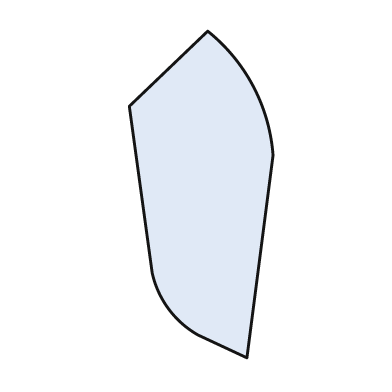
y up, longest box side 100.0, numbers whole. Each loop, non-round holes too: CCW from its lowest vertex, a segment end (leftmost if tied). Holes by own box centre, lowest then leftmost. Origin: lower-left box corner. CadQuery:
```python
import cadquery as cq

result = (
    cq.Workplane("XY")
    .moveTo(36.0, 0.0)
    .lineTo(44.0, 62.0)
    .threePointArc((38.0, 83.0), (24.0, 100.0))
    .lineTo(0.0, 77.0)
    .lineTo(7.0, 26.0)
    .threePointArc((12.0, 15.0), (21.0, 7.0))
    .close()
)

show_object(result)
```